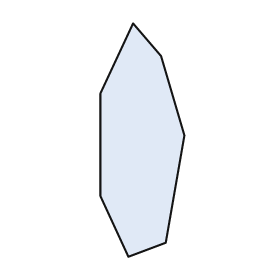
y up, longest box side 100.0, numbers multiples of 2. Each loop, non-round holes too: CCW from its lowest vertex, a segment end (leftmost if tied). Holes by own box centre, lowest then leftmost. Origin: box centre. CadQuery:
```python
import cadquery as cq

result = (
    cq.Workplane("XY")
    .moveTo(-6.0, -50.0)
    .lineTo(10.0, -44.0)
    .lineTo(18.0, 2.0)
    .lineTo(8.0, 36.0)
    .lineTo(-4.0, 50.0)
    .lineTo(-18.0, 20.0)
    .lineTo(-18.0, -24.0)
    .close()
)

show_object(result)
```